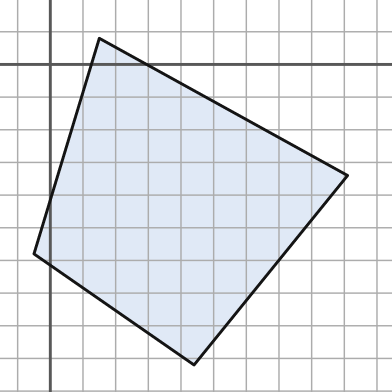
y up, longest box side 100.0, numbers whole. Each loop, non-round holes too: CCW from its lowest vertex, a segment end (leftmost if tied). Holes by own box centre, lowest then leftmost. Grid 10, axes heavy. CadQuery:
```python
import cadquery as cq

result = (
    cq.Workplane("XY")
    .moveTo(44.0, -92.0)
    .lineTo(91.0, -34.0)
    .lineTo(15.0, 8.0)
    .lineTo(-5.0, -58.0)
    .close()
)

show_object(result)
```